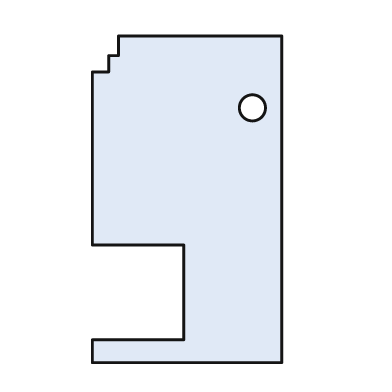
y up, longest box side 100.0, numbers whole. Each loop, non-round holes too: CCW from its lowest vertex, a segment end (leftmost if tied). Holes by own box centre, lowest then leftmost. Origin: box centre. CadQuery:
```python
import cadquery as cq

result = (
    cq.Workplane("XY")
    .moveTo(-29.0, -50.0)
    .lineTo(29.0, -50.0)
    .lineTo(29.0, 50.0)
    .lineTo(-21.0, 50.0)
    .lineTo(-21.0, 44.0)
    .lineTo(-24.0, 44.0)
    .lineTo(-24.0, 39.0)
    .lineTo(-29.0, 39.0)
    .lineTo(-29.0, -14.0)
    .lineTo(-1.0, -14.0)
    .lineTo(-1.0, -43.0)
    .lineTo(-29.0, -43.0)
    .close()
    .moveTo(20.0, 28.0)
    .circle(4.0)
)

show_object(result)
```